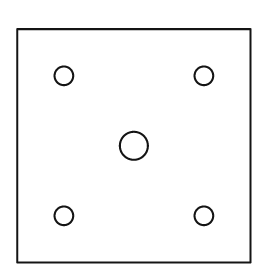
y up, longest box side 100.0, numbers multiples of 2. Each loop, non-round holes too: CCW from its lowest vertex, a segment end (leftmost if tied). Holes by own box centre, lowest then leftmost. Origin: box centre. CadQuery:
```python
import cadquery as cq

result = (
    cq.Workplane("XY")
    .moveTo(-50.0, -50.0)
    .lineTo(50.0, -50.0)
    .lineTo(50.0, 50.0)
    .lineTo(-50.0, 50.0)
    .close()
    .moveTo(-30.0, -30.0)
    .circle(4.0)
    .moveTo(30.0, -30.0)
    .circle(4.0)
    .moveTo(0.0, 0.0)
    .circle(6.0)
    .moveTo(-30.0, 30.0)
    .circle(4.0)
    .moveTo(30.0, 30.0)
    .circle(4.0)
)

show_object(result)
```